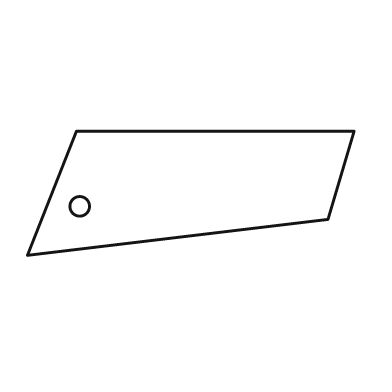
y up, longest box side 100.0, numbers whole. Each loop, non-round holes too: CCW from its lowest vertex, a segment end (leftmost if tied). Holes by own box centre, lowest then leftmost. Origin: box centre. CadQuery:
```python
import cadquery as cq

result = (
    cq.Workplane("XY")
    .moveTo(-50.0, -19.0)
    .lineTo(42.0, -8.0)
    .lineTo(50.0, 19.0)
    .lineTo(-35.0, 19.0)
    .close()
    .moveTo(-34.0, -4.0)
    .circle(3.0)
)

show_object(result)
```